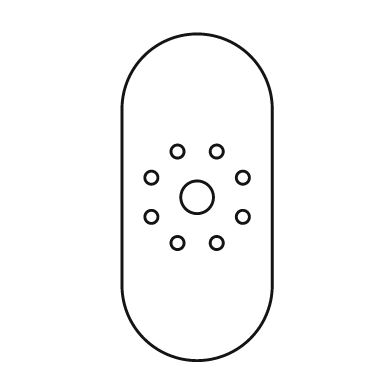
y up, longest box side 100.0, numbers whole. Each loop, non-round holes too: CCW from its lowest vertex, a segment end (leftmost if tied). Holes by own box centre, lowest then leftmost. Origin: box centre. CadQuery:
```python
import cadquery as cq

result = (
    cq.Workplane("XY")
    .moveTo(-23.0, -27.0)
    .threePointArc((0.0, -50.0), (23.0, -27.0))
    .lineTo(23.0, 27.0)
    .threePointArc((0.0, 50.0), (-23.0, 27.0))
    .close()
    .moveTo(-6.0, -14.0)
    .circle(2.0)
    .moveTo(6.0, -14.0)
    .circle(2.0)
    .moveTo(-14.0, -6.0)
    .circle(2.0)
    .moveTo(14.0, -6.0)
    .circle(2.0)
    .moveTo(0.0, 0.0)
    .circle(5.0)
    .moveTo(-14.0, 6.0)
    .circle(2.0)
    .moveTo(14.0, 6.0)
    .circle(2.0)
    .moveTo(-6.0, 14.0)
    .circle(2.0)
    .moveTo(6.0, 14.0)
    .circle(2.0)
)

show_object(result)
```